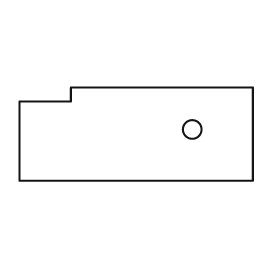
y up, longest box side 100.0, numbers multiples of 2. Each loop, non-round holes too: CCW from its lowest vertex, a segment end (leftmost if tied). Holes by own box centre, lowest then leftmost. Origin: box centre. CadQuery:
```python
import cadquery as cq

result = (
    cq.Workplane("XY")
    .moveTo(-50.0, -20.0)
    .lineTo(50.0, -20.0)
    .lineTo(50.0, 20.0)
    .lineTo(-28.0, 20.0)
    .lineTo(-28.0, 14.0)
    .lineTo(-50.0, 14.0)
    .close()
    .moveTo(24.0, 2.0)
    .circle(4.0)
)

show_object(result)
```